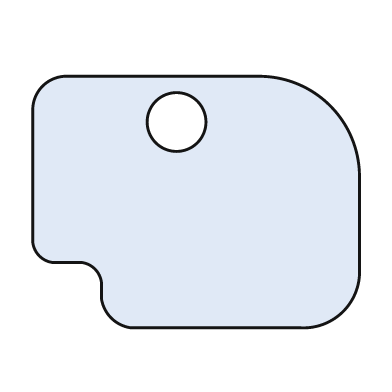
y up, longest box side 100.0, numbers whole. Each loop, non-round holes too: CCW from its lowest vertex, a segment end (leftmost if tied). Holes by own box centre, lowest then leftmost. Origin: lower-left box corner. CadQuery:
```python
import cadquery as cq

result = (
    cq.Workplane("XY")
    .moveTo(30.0, 0.0)
    .lineTo(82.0, 0.0)
    .threePointArc((95.0, 5.0), (100.0, 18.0))
    .lineTo(100.0, 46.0)
    .threePointArc((91.0, 68.0), (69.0, 77.0))
    .lineTo(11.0, 77.0)
    .threePointArc((3.0, 74.0), (0.0, 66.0))
    .lineTo(0.0, 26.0)
    .threePointArc((2.0, 22.0), (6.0, 20.0))
    .lineTo(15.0, 20.0)
    .threePointArc((19.0, 18.0), (21.0, 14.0))
    .lineTo(21.0, 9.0)
    .threePointArc((24.0, 3.0), (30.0, 0.0))
    .close()
    .moveTo(44.0, 63.0)
    .circle(9.0)
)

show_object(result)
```